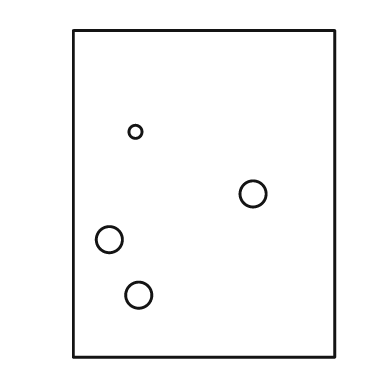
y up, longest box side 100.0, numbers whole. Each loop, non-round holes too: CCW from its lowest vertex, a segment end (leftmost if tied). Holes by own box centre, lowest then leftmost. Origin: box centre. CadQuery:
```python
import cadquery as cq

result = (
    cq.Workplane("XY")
    .moveTo(-40.0, -50.0)
    .lineTo(40.0, -50.0)
    .lineTo(40.0, 50.0)
    .lineTo(-40.0, 50.0)
    .close()
    .moveTo(-20.0, -31.0)
    .circle(4.0)
    .moveTo(-29.0, -14.0)
    .circle(4.0)
    .moveTo(15.0, 0.0)
    .circle(4.0)
    .moveTo(-21.0, 19.0)
    .circle(2.0)
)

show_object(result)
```